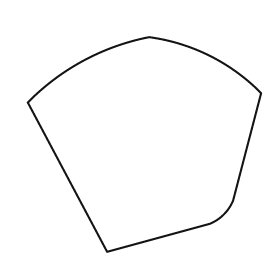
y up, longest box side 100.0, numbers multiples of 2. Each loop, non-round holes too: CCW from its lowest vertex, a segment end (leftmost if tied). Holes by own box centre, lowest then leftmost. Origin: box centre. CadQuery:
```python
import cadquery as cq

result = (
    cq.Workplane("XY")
    .moveTo(-16.0, -46.0)
    .lineTo(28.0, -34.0)
    .threePointArc((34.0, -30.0), (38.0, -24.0))
    .lineTo(50.0, 22.0)
    .threePointArc((28.0, 38.0), (2.0, 46.0))
    .threePointArc((-26.0, 36.0), (-50.0, 18.0))
    .close()
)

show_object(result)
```